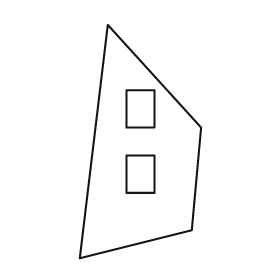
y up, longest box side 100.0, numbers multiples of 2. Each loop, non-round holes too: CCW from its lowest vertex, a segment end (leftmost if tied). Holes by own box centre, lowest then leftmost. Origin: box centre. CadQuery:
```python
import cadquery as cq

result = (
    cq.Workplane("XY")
    .moveTo(-26.0, -50.0)
    .lineTo(22.0, -38.0)
    .lineTo(26.0, 6.0)
    .lineTo(-14.0, 50.0)
    .close()
    .moveTo(-6.0, -22.0)
    .lineTo(6.0, -22.0)
    .lineTo(6.0, -6.0)
    .lineTo(-6.0, -6.0)
    .close()
    .moveTo(-6.0, 6.0)
    .lineTo(6.0, 6.0)
    .lineTo(6.0, 22.0)
    .lineTo(-6.0, 22.0)
    .close()
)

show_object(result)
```